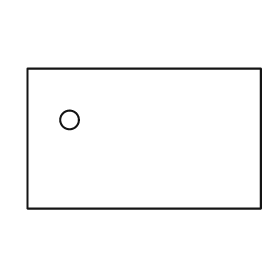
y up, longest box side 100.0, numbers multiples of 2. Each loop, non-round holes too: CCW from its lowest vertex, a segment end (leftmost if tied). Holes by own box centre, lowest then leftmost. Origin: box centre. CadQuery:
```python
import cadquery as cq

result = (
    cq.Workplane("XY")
    .moveTo(-50.0, -30.0)
    .lineTo(50.0, -30.0)
    .lineTo(50.0, 30.0)
    .lineTo(-50.0, 30.0)
    .close()
    .moveTo(-32.0, 8.0)
    .circle(4.0)
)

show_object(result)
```